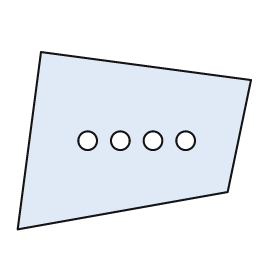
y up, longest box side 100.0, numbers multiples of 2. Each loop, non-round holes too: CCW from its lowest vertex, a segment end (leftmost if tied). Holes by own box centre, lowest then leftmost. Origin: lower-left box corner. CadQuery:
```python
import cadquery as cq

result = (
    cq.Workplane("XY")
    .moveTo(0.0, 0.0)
    .lineTo(90.0, 16.0)
    .lineTo(100.0, 64.0)
    .lineTo(10.0, 76.0)
    .close()
    .moveTo(30.0, 38.0)
    .circle(4.0)
    .moveTo(44.0, 38.0)
    .circle(4.0)
    .moveTo(58.0, 38.0)
    .circle(4.0)
    .moveTo(72.0, 38.0)
    .circle(4.0)
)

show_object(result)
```